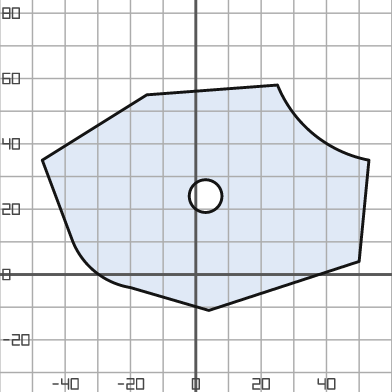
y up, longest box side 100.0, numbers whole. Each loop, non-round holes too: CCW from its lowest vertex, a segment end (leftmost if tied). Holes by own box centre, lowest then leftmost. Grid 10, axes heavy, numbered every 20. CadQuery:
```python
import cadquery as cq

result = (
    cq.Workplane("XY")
    .moveTo(4.0, -11.0)
    .lineTo(50.0, 4.0)
    .lineTo(53.0, 35.0)
    .threePointArc((36.0, 43.0), (25.0, 58.0))
    .lineTo(-15.0, 55.0)
    .lineTo(-47.0, 35.0)
    .lineTo(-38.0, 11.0)
    .threePointArc((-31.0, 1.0), (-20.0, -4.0))
    .close()
    .moveTo(3.0, 24.0)
    .circle(5.0)
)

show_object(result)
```